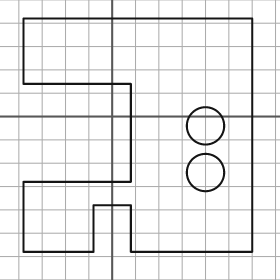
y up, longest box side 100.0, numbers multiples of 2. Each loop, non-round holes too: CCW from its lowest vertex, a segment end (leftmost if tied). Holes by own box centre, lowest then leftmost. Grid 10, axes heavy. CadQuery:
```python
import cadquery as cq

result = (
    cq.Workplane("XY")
    .moveTo(-38.0, -58.0)
    .lineTo(-8.0, -58.0)
    .lineTo(-8.0, -38.0)
    .lineTo(8.0, -38.0)
    .lineTo(8.0, -58.0)
    .lineTo(60.0, -58.0)
    .lineTo(60.0, 42.0)
    .lineTo(-38.0, 42.0)
    .lineTo(-38.0, 14.0)
    .lineTo(8.0, 14.0)
    .lineTo(8.0, -28.0)
    .lineTo(-38.0, -28.0)
    .close()
    .moveTo(40.0, -24.0)
    .circle(8.0)
    .moveTo(40.0, -4.0)
    .circle(8.0)
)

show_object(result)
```